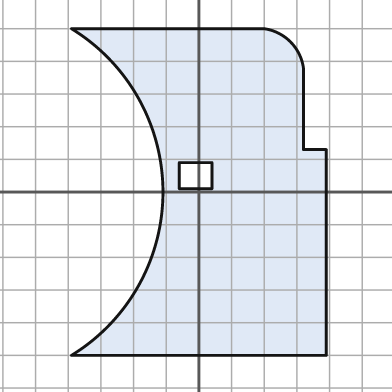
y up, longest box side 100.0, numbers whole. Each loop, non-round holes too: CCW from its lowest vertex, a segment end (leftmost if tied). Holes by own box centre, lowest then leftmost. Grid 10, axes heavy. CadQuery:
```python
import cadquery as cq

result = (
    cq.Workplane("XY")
    .moveTo(-39.0, -50.0)
    .lineTo(39.0, -50.0)
    .lineTo(39.0, 13.0)
    .lineTo(32.0, 13.0)
    .lineTo(32.0, 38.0)
    .threePointArc((28.0, 46.0), (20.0, 50.0))
    .lineTo(-39.0, 50.0)
    .threePointArc((-11.0, 0.0), (-39.0, -50.0))
    .close()
    .moveTo(-6.0, 1.0)
    .lineTo(4.0, 1.0)
    .lineTo(4.0, 9.0)
    .lineTo(-6.0, 9.0)
    .close()
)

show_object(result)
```